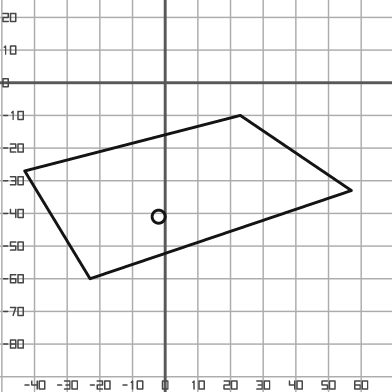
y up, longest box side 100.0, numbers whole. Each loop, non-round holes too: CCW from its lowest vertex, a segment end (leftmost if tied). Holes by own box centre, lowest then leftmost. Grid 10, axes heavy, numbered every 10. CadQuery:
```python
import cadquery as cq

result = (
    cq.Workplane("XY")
    .moveTo(-23.0, -60.0)
    .lineTo(57.0, -33.0)
    .lineTo(23.0, -10.0)
    .lineTo(-43.0, -27.0)
    .close()
    .moveTo(-2.0, -41.0)
    .circle(2.0)
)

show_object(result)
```